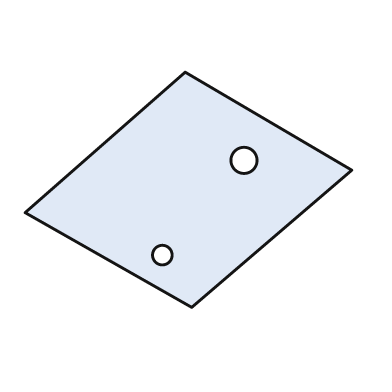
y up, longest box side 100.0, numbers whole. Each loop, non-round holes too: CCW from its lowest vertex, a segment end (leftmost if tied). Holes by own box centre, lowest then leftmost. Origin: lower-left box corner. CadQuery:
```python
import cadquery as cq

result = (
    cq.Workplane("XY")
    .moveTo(51.0, 0.0)
    .lineTo(100.0, 42.0)
    .lineTo(49.0, 72.0)
    .lineTo(0.0, 29.0)
    .close()
    .moveTo(42.0, 16.0)
    .circle(3.0)
    .moveTo(67.0, 45.0)
    .circle(4.0)
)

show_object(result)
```